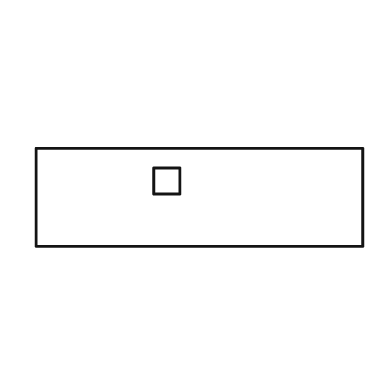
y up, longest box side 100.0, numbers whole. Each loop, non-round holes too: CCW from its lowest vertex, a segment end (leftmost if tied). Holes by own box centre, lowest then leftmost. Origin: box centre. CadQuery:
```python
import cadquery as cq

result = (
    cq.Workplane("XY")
    .moveTo(-50.0, -15.0)
    .lineTo(50.0, -15.0)
    .lineTo(50.0, 15.0)
    .lineTo(-50.0, 15.0)
    .close()
    .moveTo(-14.0, 1.0)
    .lineTo(-6.0, 1.0)
    .lineTo(-6.0, 9.0)
    .lineTo(-14.0, 9.0)
    .close()
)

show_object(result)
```